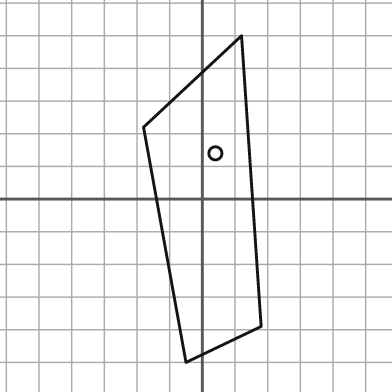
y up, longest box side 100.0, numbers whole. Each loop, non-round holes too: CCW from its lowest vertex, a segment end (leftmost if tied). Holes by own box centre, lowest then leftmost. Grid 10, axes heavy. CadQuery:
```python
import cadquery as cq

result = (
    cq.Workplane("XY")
    .moveTo(-5.0, -50.0)
    .lineTo(18.0, -39.0)
    .lineTo(12.0, 50.0)
    .lineTo(-18.0, 22.0)
    .close()
    .moveTo(4.0, 14.0)
    .circle(2.0)
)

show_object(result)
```